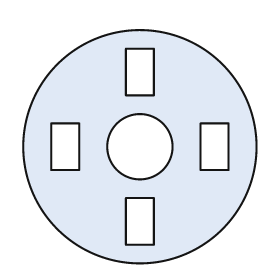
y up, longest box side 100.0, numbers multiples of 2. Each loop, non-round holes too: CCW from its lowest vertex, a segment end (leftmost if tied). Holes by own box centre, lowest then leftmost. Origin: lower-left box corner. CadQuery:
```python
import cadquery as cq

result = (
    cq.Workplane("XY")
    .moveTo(50.0, 50.0)
    .circle(50.0)
    .moveTo(44.0, 8.0)
    .lineTo(56.0, 8.0)
    .lineTo(56.0, 28.0)
    .lineTo(44.0, 28.0)
    .close()
    .moveTo(12.0, 40.0)
    .lineTo(24.0, 40.0)
    .lineTo(24.0, 60.0)
    .lineTo(12.0, 60.0)
    .close()
    .moveTo(50.0, 50.0)
    .circle(14.0)
    .moveTo(76.0, 40.0)
    .lineTo(88.0, 40.0)
    .lineTo(88.0, 60.0)
    .lineTo(76.0, 60.0)
    .close()
    .moveTo(44.0, 72.0)
    .lineTo(56.0, 72.0)
    .lineTo(56.0, 92.0)
    .lineTo(44.0, 92.0)
    .close()
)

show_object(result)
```